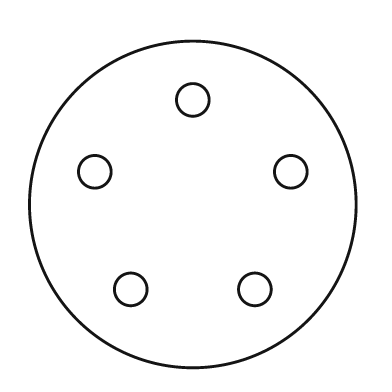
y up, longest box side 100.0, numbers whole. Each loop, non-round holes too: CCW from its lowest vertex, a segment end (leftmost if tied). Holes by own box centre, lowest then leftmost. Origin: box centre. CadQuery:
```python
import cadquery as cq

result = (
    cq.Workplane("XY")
    .moveTo(0.0, 0.0)
    .circle(50.0)
    .moveTo(-19.0, -26.0)
    .circle(5.0)
    .moveTo(19.0, -26.0)
    .circle(5.0)
    .moveTo(-30.0, 10.0)
    .circle(5.0)
    .moveTo(30.0, 10.0)
    .circle(5.0)
    .moveTo(0.0, 32.0)
    .circle(5.0)
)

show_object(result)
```